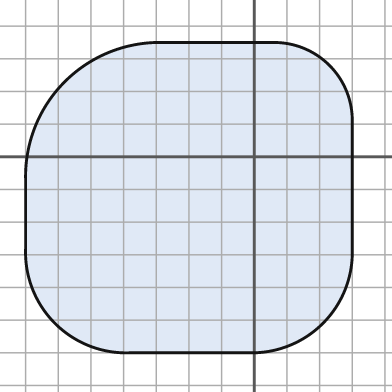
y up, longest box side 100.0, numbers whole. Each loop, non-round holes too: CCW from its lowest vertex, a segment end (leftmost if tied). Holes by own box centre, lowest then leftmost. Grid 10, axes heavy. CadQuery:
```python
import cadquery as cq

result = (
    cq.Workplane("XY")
    .moveTo(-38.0, -60.0)
    .lineTo(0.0, -60.0)
    .threePointArc((21.0, -51.0), (30.0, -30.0))
    .lineTo(30.0, 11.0)
    .threePointArc((23.0, 28.0), (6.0, 35.0))
    .lineTo(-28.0, 35.0)
    .threePointArc((-58.0, 23.0), (-70.0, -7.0))
    .lineTo(-70.0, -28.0)
    .threePointArc((-61.0, -51.0), (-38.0, -60.0))
    .close()
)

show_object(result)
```